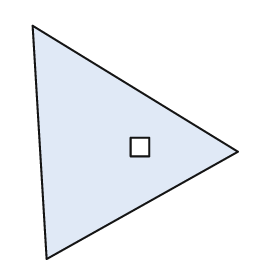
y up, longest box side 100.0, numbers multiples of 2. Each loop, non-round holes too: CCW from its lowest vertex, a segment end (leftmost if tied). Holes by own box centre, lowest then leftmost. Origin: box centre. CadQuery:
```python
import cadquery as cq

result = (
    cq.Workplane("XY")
    .moveTo(-38.0, -50.0)
    .lineTo(44.0, -4.0)
    .lineTo(-44.0, 50.0)
    .close()
    .moveTo(-2.0, -6.0)
    .lineTo(6.0, -6.0)
    .lineTo(6.0, 2.0)
    .lineTo(-2.0, 2.0)
    .close()
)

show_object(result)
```